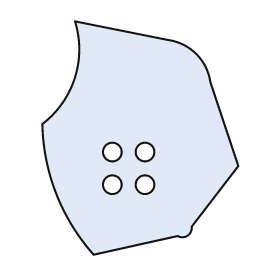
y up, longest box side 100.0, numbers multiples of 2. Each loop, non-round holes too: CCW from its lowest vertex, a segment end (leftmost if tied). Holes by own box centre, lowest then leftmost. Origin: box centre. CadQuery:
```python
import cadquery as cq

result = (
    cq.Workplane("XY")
    .moveTo(-20.0, -50.0)
    .lineTo(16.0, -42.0)
    .threePointArc((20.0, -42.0), (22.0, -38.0))
    .lineTo(42.0, -12.0)
    .lineTo(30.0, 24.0)
    .threePointArc((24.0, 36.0), (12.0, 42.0))
    .lineTo(-28.0, 50.0)
    .threePointArc((-28.0, 26.0), (-42.0, 6.0))
    .threePointArc((-36.0, -24.0), (-20.0, -50.0))
    .close()
    .moveTo(-12.0, -20.0)
    .circle(4.0)
    .moveTo(2.0, -20.0)
    .circle(4.0)
    .moveTo(-12.0, -6.0)
    .circle(4.0)
    .moveTo(2.0, -6.0)
    .circle(4.0)
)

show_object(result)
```